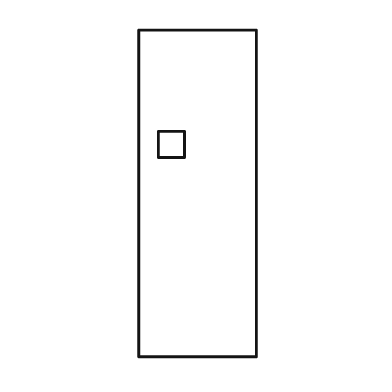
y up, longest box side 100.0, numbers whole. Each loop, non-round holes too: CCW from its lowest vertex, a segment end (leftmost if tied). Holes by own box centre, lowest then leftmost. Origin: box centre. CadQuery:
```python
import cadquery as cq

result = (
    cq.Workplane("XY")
    .moveTo(-18.0, -50.0)
    .lineTo(18.0, -50.0)
    .lineTo(18.0, 50.0)
    .lineTo(-18.0, 50.0)
    .close()
    .moveTo(-12.0, 11.0)
    .lineTo(-4.0, 11.0)
    .lineTo(-4.0, 19.0)
    .lineTo(-12.0, 19.0)
    .close()
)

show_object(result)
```